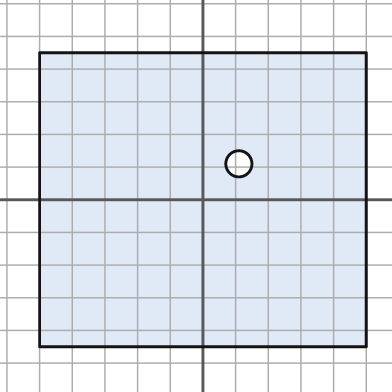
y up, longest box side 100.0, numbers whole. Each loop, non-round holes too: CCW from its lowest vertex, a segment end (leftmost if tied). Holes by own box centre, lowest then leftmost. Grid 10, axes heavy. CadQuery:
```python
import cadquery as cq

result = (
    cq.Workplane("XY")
    .moveTo(-50.0, -45.0)
    .lineTo(50.0, -45.0)
    .lineTo(50.0, 45.0)
    .lineTo(-50.0, 45.0)
    .close()
    .moveTo(11.0, 11.0)
    .circle(4.0)
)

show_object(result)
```